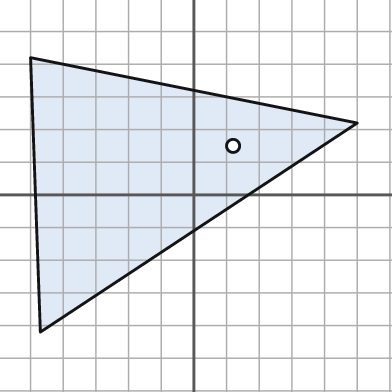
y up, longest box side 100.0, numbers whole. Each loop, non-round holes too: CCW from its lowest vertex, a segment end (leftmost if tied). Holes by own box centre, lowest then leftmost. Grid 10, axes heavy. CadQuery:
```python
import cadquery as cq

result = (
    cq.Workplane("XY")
    .moveTo(-47.0, -42.0)
    .lineTo(50.0, 22.0)
    .lineTo(-50.0, 42.0)
    .close()
    .moveTo(12.0, 15.0)
    .circle(2.0)
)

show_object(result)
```